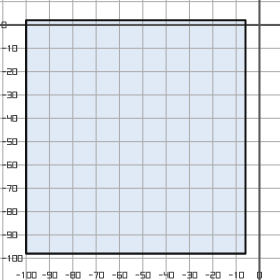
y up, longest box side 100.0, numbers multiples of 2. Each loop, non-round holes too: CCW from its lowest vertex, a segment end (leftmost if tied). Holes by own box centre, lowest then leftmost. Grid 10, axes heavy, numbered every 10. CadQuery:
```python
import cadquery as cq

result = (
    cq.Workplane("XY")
    .moveTo(-100.0, -98.0)
    .lineTo(-6.0, -98.0)
    .lineTo(-6.0, 2.0)
    .lineTo(-100.0, 2.0)
    .close()
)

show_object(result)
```